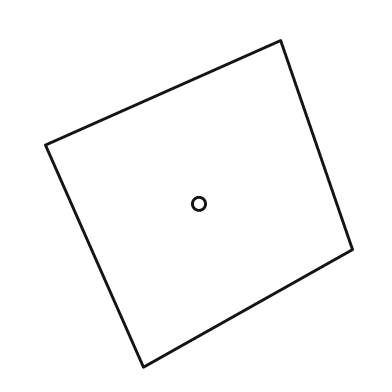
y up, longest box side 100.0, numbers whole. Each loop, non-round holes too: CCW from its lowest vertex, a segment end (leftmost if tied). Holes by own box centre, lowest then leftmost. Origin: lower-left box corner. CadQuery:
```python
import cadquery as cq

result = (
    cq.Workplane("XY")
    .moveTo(30.0, 0.0)
    .lineTo(94.0, 36.0)
    .lineTo(72.0, 100.0)
    .lineTo(0.0, 68.0)
    .close()
    .moveTo(47.0, 50.0)
    .circle(2.0)
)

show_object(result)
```